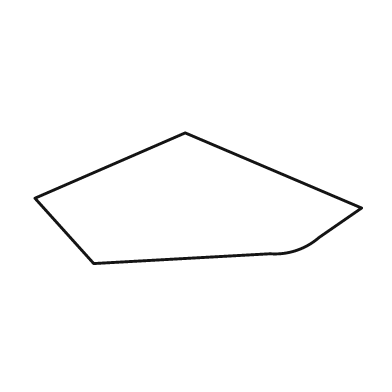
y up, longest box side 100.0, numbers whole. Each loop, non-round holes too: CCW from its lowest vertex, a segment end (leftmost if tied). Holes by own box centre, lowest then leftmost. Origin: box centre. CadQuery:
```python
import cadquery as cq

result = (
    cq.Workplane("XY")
    .moveTo(-32.0, -20.0)
    .lineTo(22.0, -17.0)
    .threePointArc((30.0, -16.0), (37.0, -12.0))
    .lineTo(50.0, -3.0)
    .lineTo(-4.0, 20.0)
    .lineTo(-50.0, 0.0)
    .close()
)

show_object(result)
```